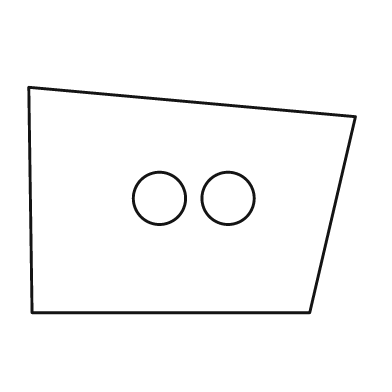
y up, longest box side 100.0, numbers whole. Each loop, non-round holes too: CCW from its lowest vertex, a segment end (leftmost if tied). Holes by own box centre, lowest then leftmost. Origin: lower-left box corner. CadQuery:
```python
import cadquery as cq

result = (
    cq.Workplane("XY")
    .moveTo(1.0, 0.0)
    .lineTo(86.0, 0.0)
    .lineTo(100.0, 60.0)
    .lineTo(0.0, 69.0)
    .close()
    .moveTo(40.0, 35.0)
    .circle(8.0)
    .moveTo(61.0, 35.0)
    .circle(8.0)
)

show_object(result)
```